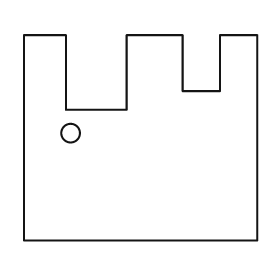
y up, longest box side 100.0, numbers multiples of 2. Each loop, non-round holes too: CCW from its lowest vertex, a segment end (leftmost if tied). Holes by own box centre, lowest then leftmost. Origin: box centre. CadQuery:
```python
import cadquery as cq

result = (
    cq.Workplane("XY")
    .moveTo(-50.0, -44.0)
    .lineTo(50.0, -44.0)
    .lineTo(50.0, 44.0)
    .lineTo(34.0, 44.0)
    .lineTo(34.0, 20.0)
    .lineTo(18.0, 20.0)
    .lineTo(18.0, 44.0)
    .lineTo(-6.0, 44.0)
    .lineTo(-6.0, 12.0)
    .lineTo(-32.0, 12.0)
    .lineTo(-32.0, 44.0)
    .lineTo(-50.0, 44.0)
    .close()
    .moveTo(-30.0, 2.0)
    .circle(4.0)
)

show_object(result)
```